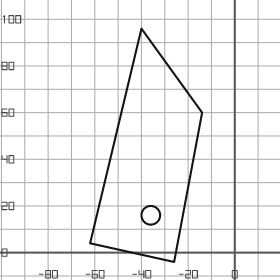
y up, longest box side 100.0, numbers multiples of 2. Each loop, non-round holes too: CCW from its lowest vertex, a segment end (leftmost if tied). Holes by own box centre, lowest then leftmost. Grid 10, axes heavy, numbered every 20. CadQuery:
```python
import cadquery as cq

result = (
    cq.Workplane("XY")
    .moveTo(-26.0, -4.0)
    .lineTo(-14.0, 60.0)
    .lineTo(-40.0, 96.0)
    .lineTo(-62.0, 4.0)
    .close()
    .moveTo(-36.0, 16.0)
    .circle(4.0)
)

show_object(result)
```